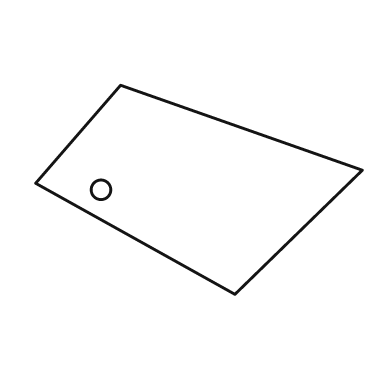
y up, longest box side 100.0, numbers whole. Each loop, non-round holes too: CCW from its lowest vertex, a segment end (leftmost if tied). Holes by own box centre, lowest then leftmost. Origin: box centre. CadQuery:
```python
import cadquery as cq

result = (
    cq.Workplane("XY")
    .moveTo(11.0, -32.0)
    .lineTo(50.0, 6.0)
    .lineTo(-24.0, 32.0)
    .lineTo(-50.0, 2.0)
    .close()
    .moveTo(-30.0, 0.0)
    .circle(3.0)
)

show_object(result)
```